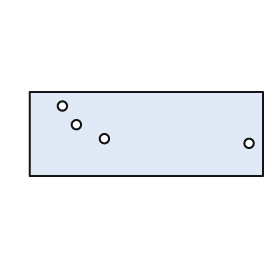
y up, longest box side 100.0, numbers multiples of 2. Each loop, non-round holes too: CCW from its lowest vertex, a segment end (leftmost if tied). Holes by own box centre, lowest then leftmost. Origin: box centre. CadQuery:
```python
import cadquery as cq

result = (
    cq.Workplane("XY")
    .moveTo(-50.0, -18.0)
    .lineTo(50.0, -18.0)
    .lineTo(50.0, 18.0)
    .lineTo(-50.0, 18.0)
    .close()
    .moveTo(44.0, -4.0)
    .circle(2.0)
    .moveTo(-18.0, -2.0)
    .circle(2.0)
    .moveTo(-30.0, 4.0)
    .circle(2.0)
    .moveTo(-36.0, 12.0)
    .circle(2.0)
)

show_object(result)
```